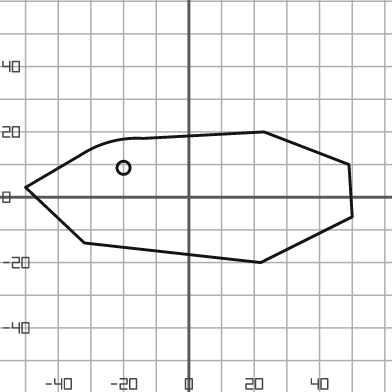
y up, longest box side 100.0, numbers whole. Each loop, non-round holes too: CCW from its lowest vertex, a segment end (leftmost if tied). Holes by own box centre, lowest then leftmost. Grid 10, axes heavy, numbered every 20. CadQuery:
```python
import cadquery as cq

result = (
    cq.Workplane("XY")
    .moveTo(22.0, -20.0)
    .lineTo(50.0, -6.0)
    .lineTo(49.0, 10.0)
    .lineTo(23.0, 20.0)
    .lineTo(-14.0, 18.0)
    .threePointArc((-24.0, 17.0), (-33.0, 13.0))
    .lineTo(-50.0, 3.0)
    .lineTo(-32.0, -14.0)
    .close()
    .moveTo(-20.0, 9.0)
    .circle(2.0)
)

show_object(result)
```